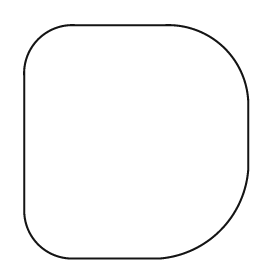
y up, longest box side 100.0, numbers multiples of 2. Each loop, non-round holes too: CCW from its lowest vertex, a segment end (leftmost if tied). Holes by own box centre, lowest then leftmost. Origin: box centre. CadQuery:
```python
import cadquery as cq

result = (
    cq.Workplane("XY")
    .moveTo(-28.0, -50.0)
    .lineTo(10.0, -50.0)
    .threePointArc((36.0, -38.0), (48.0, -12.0))
    .lineTo(48.0, 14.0)
    .threePointArc((38.0, 40.0), (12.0, 50.0))
    .lineTo(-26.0, 50.0)
    .threePointArc((-42.0, 44.0), (-48.0, 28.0))
    .lineTo(-48.0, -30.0)
    .threePointArc((-42.0, -44.0), (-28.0, -50.0))
    .close()
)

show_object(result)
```